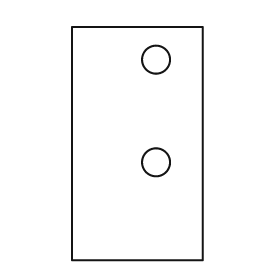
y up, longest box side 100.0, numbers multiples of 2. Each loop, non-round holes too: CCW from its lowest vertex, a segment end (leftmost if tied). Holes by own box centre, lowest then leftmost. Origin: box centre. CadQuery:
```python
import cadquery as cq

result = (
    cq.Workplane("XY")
    .moveTo(-28.0, -50.0)
    .lineTo(28.0, -50.0)
    .lineTo(28.0, 50.0)
    .lineTo(-28.0, 50.0)
    .close()
    .moveTo(8.0, -8.0)
    .circle(6.0)
    .moveTo(8.0, 36.0)
    .circle(6.0)
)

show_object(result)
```